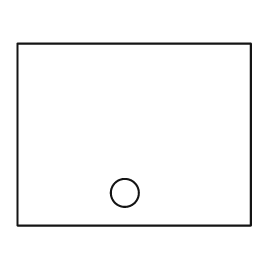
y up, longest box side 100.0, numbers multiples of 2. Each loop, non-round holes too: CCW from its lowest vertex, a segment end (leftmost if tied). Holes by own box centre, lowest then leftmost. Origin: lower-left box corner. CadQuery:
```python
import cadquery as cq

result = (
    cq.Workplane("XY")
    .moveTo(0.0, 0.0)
    .lineTo(100.0, 0.0)
    .lineTo(100.0, 78.0)
    .lineTo(0.0, 78.0)
    .close()
    .moveTo(46.0, 14.0)
    .circle(6.0)
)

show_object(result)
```